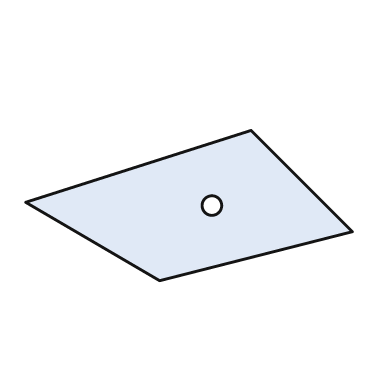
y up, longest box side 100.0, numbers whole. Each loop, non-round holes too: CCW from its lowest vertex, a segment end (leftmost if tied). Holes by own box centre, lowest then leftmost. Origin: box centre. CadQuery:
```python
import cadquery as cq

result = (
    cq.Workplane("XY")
    .moveTo(-9.0, -23.0)
    .lineTo(50.0, -8.0)
    .lineTo(19.0, 23.0)
    .lineTo(-50.0, 1.0)
    .close()
    .moveTo(7.0, 0.0)
    .circle(3.0)
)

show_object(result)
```